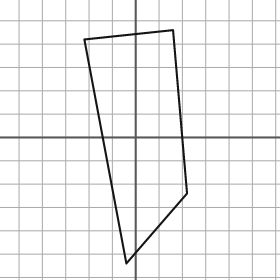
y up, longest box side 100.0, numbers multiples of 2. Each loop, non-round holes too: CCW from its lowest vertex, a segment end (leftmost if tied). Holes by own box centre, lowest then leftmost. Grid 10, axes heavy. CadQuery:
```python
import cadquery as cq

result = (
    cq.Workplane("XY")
    .moveTo(-4.0, -54.0)
    .lineTo(22.0, -24.0)
    .lineTo(16.0, 46.0)
    .lineTo(-22.0, 42.0)
    .close()
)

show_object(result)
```